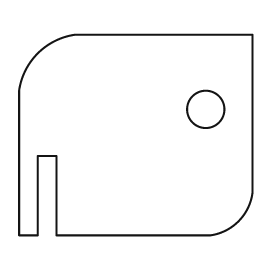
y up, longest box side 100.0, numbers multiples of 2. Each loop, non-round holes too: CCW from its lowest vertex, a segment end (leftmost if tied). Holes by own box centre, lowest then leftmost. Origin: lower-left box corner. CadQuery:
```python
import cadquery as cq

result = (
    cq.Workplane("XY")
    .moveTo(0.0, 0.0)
    .lineTo(8.0, 0.0)
    .lineTo(8.0, 34.0)
    .lineTo(16.0, 34.0)
    .lineTo(16.0, 0.0)
    .lineTo(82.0, 0.0)
    .threePointArc((94.0, 6.0), (100.0, 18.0))
    .lineTo(100.0, 86.0)
    .lineTo(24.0, 86.0)
    .threePointArc((8.0, 78.0), (0.0, 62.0))
    .close()
    .moveTo(80.0, 54.0)
    .circle(8.0)
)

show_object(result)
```